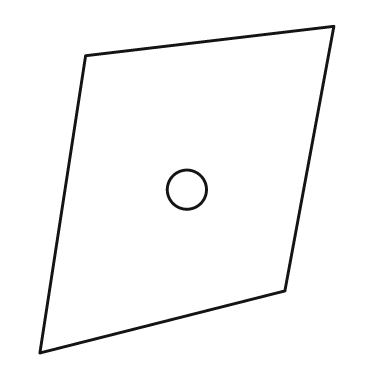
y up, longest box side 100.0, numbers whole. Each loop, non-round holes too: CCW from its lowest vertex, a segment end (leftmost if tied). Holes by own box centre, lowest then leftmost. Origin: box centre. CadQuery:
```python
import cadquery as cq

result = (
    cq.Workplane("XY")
    .moveTo(-45.0, -50.0)
    .lineTo(30.0, -31.0)
    .lineTo(45.0, 50.0)
    .lineTo(-31.0, 41.0)
    .close()
    .moveTo(0.0, 0.0)
    .circle(6.0)
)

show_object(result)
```